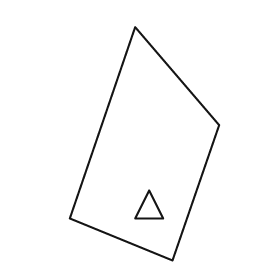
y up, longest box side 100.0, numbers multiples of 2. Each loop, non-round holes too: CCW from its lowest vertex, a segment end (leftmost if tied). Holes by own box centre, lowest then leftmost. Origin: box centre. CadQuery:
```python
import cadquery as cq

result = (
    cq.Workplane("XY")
    .moveTo(12.0, -50.0)
    .lineTo(32.0, 8.0)
    .lineTo(-4.0, 50.0)
    .lineTo(-32.0, -32.0)
    .close()
    .moveTo(-4.0, -32.0)
    .lineTo(8.0, -32.0)
    .lineTo(2.0, -20.0)
    .close()
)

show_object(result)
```